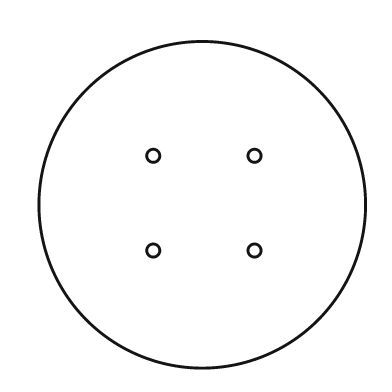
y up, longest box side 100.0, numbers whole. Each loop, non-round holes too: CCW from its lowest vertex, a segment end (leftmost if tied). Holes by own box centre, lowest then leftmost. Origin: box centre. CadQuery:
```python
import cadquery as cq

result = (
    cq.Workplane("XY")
    .moveTo(0.0, 0.0)
    .circle(50.0)
    .moveTo(-15.0, -14.0)
    .circle(2.0)
    .moveTo(16.0, -14.0)
    .circle(2.0)
    .moveTo(-15.0, 15.0)
    .circle(2.0)
    .moveTo(16.0, 15.0)
    .circle(2.0)
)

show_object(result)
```